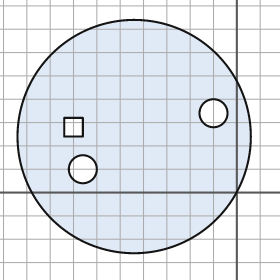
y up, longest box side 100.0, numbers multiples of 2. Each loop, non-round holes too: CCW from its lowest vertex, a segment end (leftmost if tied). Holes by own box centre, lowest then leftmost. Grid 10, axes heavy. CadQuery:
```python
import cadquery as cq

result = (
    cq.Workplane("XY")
    .moveTo(-44.0, 24.0)
    .circle(50.0)
    .moveTo(-66.0, 10.0)
    .circle(6.0)
    .moveTo(-74.0, 24.0)
    .lineTo(-66.0, 24.0)
    .lineTo(-66.0, 32.0)
    .lineTo(-74.0, 32.0)
    .close()
    .moveTo(-10.0, 34.0)
    .circle(6.0)
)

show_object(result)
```